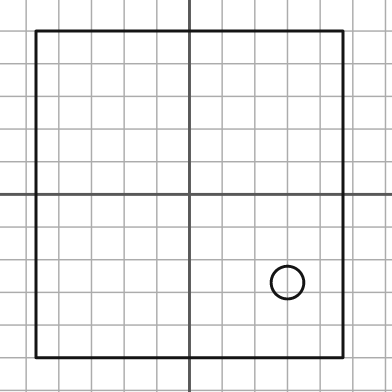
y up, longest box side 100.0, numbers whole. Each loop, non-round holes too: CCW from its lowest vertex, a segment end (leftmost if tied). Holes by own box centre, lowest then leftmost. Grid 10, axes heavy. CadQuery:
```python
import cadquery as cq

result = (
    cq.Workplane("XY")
    .moveTo(-47.0, -50.0)
    .lineTo(47.0, -50.0)
    .lineTo(47.0, 50.0)
    .lineTo(-47.0, 50.0)
    .close()
    .moveTo(30.0, -27.0)
    .circle(5.0)
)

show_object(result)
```